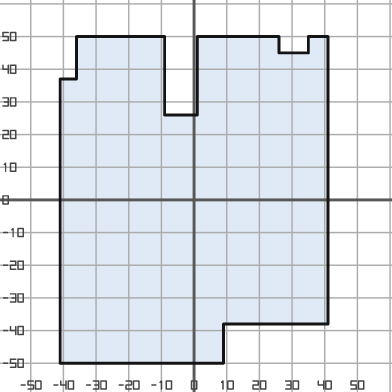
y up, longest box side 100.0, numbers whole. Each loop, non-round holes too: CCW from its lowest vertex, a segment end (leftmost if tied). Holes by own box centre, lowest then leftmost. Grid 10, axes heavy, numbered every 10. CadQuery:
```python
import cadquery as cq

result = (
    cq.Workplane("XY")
    .moveTo(-41.0, -50.0)
    .lineTo(9.0, -50.0)
    .lineTo(9.0, -38.0)
    .lineTo(41.0, -38.0)
    .lineTo(41.0, 50.0)
    .lineTo(35.0, 50.0)
    .lineTo(35.0, 45.0)
    .lineTo(26.0, 45.0)
    .lineTo(26.0, 50.0)
    .lineTo(1.0, 50.0)
    .lineTo(1.0, 26.0)
    .lineTo(-9.0, 26.0)
    .lineTo(-9.0, 50.0)
    .lineTo(-36.0, 50.0)
    .lineTo(-36.0, 37.0)
    .lineTo(-41.0, 37.0)
    .close()
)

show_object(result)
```